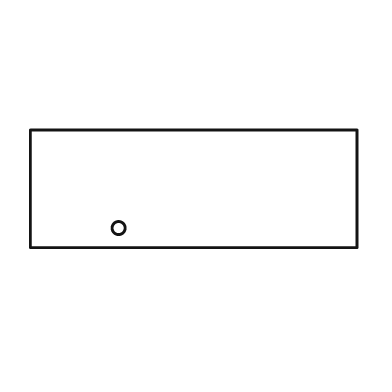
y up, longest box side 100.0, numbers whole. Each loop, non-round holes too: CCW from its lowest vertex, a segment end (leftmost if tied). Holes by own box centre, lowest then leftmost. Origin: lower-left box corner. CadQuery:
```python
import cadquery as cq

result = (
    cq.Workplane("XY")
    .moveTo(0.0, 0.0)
    .lineTo(100.0, 0.0)
    .lineTo(100.0, 36.0)
    .lineTo(0.0, 36.0)
    .close()
    .moveTo(27.0, 6.0)
    .circle(2.0)
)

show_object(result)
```